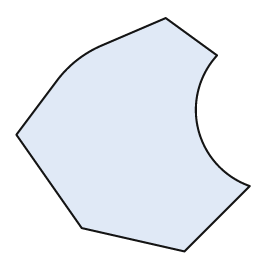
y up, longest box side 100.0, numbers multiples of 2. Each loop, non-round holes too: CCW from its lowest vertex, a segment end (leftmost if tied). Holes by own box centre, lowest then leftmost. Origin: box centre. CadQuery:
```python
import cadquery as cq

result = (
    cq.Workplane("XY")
    .moveTo(22.0, -50.0)
    .lineTo(50.0, -22.0)
    .threePointArc((28.0, 2.0), (36.0, 34.0))
    .lineTo(14.0, 50.0)
    .lineTo(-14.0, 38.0)
    .threePointArc((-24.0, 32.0), (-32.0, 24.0))
    .lineTo(-50.0, 0.0)
    .lineTo(-22.0, -40.0)
    .close()
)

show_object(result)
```